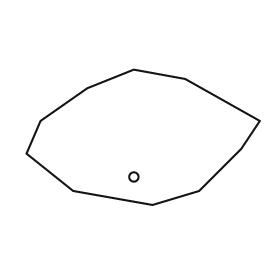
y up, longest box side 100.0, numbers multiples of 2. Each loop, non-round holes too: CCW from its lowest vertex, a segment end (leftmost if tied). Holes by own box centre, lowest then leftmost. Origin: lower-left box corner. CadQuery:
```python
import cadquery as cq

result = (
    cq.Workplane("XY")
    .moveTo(54.0, 0.0)
    .lineTo(74.0, 6.0)
    .lineTo(92.0, 24.0)
    .lineTo(100.0, 36.0)
    .lineTo(68.0, 54.0)
    .lineTo(46.0, 58.0)
    .lineTo(26.0, 50.0)
    .lineTo(6.0, 36.0)
    .lineTo(0.0, 22.0)
    .lineTo(20.0, 6.0)
    .close()
    .moveTo(46.0, 12.0)
    .circle(2.0)
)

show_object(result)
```